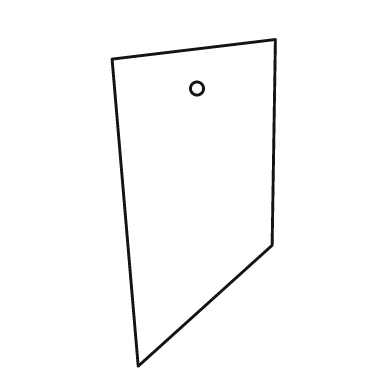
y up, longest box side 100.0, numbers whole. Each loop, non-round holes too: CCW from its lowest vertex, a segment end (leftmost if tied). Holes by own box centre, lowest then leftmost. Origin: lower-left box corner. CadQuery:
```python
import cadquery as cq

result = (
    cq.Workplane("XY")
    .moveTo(8.0, 0.0)
    .lineTo(49.0, 37.0)
    .lineTo(50.0, 100.0)
    .lineTo(0.0, 94.0)
    .close()
    .moveTo(26.0, 85.0)
    .circle(2.0)
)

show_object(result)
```